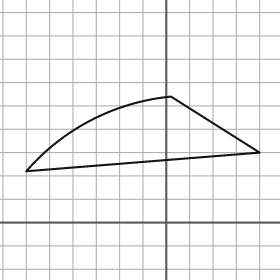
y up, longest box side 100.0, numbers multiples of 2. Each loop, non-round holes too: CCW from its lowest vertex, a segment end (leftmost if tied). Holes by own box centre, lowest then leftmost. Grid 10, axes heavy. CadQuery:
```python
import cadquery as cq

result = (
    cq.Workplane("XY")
    .moveTo(-60.0, 22.0)
    .lineTo(40.0, 30.0)
    .lineTo(2.0, 54.0)
    .threePointArc((-32.0, 44.0), (-60.0, 22.0))
    .close()
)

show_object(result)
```